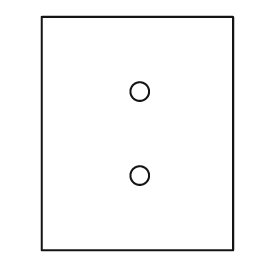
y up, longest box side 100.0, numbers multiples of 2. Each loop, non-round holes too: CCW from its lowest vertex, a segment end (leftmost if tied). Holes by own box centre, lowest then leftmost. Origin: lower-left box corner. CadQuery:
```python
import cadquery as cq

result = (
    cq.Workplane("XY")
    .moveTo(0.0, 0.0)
    .lineTo(82.0, 0.0)
    .lineTo(82.0, 100.0)
    .lineTo(0.0, 100.0)
    .close()
    .moveTo(42.0, 32.0)
    .circle(4.0)
    .moveTo(42.0, 68.0)
    .circle(4.0)
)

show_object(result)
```